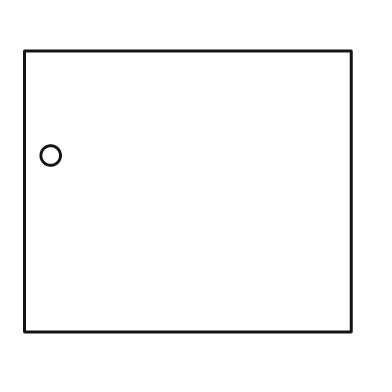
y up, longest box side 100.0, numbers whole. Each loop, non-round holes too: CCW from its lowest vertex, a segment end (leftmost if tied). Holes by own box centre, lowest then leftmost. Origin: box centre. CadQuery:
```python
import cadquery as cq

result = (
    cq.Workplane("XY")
    .moveTo(-50.0, -43.0)
    .lineTo(50.0, -43.0)
    .lineTo(50.0, 43.0)
    .lineTo(-50.0, 43.0)
    .close()
    .moveTo(-42.0, 11.0)
    .circle(3.0)
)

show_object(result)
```